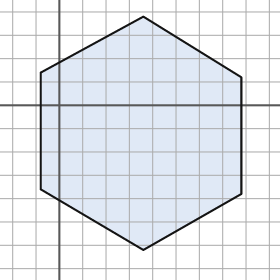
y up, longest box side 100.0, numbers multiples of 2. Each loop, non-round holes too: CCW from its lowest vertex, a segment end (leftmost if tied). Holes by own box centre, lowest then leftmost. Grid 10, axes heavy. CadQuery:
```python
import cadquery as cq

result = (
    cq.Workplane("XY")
    .moveTo(36.0, -62.0)
    .lineTo(78.0, -38.0)
    .lineTo(78.0, 12.0)
    .lineTo(36.0, 38.0)
    .lineTo(-8.0, 14.0)
    .lineTo(-8.0, -36.0)
    .close()
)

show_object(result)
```